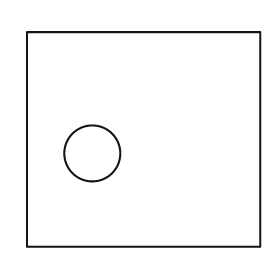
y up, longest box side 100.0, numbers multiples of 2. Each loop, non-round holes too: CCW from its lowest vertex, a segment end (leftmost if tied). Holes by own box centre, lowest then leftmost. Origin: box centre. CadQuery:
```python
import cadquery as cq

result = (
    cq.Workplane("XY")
    .moveTo(-50.0, -46.0)
    .lineTo(50.0, -46.0)
    .lineTo(50.0, 46.0)
    .lineTo(-50.0, 46.0)
    .close()
    .moveTo(-22.0, -6.0)
    .circle(12.0)
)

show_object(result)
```